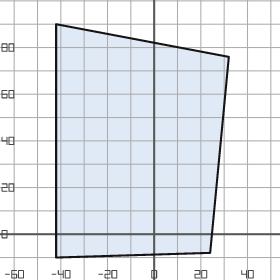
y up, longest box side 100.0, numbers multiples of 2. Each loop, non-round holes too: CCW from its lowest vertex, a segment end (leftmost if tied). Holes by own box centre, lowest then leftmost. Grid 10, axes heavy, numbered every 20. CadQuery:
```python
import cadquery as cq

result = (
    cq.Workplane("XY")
    .moveTo(-42.0, -10.0)
    .lineTo(24.0, -8.0)
    .lineTo(32.0, 76.0)
    .lineTo(-42.0, 90.0)
    .close()
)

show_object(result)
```